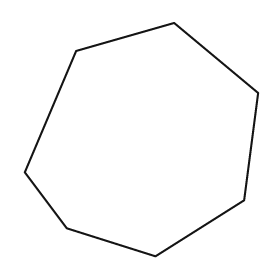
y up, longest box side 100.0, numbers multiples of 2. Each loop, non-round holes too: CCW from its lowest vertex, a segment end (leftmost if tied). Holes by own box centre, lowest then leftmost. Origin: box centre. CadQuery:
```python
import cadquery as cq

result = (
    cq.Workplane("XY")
    .moveTo(6.0, -50.0)
    .lineTo(44.0, -26.0)
    .lineTo(50.0, 20.0)
    .lineTo(14.0, 50.0)
    .lineTo(-28.0, 38.0)
    .lineTo(-50.0, -14.0)
    .lineTo(-32.0, -38.0)
    .close()
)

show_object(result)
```